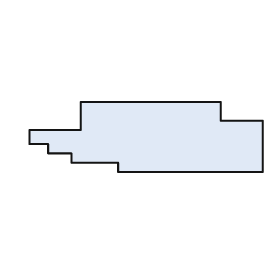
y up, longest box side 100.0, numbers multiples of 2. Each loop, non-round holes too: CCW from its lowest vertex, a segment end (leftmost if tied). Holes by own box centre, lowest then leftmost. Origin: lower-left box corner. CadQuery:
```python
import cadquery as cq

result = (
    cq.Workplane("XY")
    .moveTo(38.0, 0.0)
    .lineTo(100.0, 0.0)
    .lineTo(100.0, 22.0)
    .lineTo(82.0, 22.0)
    .lineTo(82.0, 30.0)
    .lineTo(22.0, 30.0)
    .lineTo(22.0, 18.0)
    .lineTo(0.0, 18.0)
    .lineTo(0.0, 12.0)
    .lineTo(8.0, 12.0)
    .lineTo(8.0, 8.0)
    .lineTo(18.0, 8.0)
    .lineTo(18.0, 4.0)
    .lineTo(38.0, 4.0)
    .close()
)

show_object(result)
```